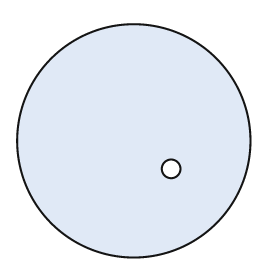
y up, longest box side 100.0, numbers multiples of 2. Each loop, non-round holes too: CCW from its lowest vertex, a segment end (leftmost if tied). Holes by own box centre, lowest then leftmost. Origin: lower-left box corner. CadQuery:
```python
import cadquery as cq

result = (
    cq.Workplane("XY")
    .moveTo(50.0, 50.0)
    .circle(50.0)
    .moveTo(66.0, 38.0)
    .circle(4.0)
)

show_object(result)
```